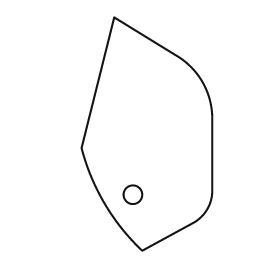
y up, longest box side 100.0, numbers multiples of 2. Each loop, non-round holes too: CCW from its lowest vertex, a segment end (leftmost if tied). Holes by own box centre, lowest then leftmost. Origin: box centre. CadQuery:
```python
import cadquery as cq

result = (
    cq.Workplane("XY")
    .moveTo(-2.0, -50.0)
    .lineTo(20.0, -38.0)
    .threePointArc((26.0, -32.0), (28.0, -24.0))
    .lineTo(28.0, 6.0)
    .threePointArc((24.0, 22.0), (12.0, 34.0))
    .lineTo(-14.0, 50.0)
    .lineTo(-28.0, -6.0)
    .threePointArc((-18.0, -30.0), (-2.0, -50.0))
    .close()
    .moveTo(-6.0, -26.0)
    .circle(4.0)
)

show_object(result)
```